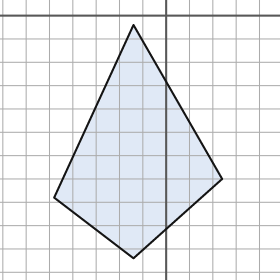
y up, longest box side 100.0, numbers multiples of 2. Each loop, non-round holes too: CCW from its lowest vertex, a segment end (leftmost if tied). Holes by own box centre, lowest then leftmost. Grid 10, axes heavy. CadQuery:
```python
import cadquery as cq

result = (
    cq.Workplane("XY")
    .moveTo(-14.0, -104.0)
    .lineTo(24.0, -70.0)
    .lineTo(-14.0, -4.0)
    .lineTo(-48.0, -78.0)
    .close()
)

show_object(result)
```